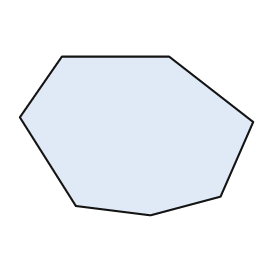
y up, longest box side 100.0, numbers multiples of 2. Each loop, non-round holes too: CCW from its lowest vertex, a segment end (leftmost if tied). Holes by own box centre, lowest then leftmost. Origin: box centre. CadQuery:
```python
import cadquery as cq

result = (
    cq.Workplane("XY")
    .moveTo(6.0, -34.0)
    .lineTo(36.0, -26.0)
    .lineTo(50.0, 6.0)
    .lineTo(14.0, 34.0)
    .lineTo(-32.0, 34.0)
    .lineTo(-50.0, 8.0)
    .lineTo(-26.0, -30.0)
    .close()
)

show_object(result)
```